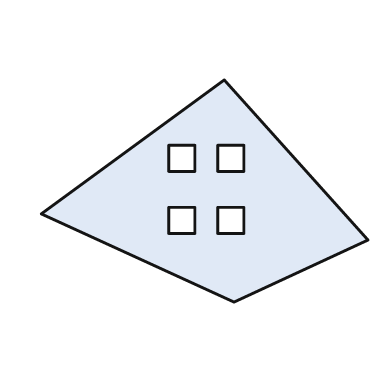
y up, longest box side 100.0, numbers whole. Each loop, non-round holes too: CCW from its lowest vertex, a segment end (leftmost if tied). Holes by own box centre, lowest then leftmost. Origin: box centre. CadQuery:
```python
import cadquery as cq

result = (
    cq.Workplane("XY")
    .moveTo(9.0, -34.0)
    .lineTo(50.0, -15.0)
    .lineTo(6.0, 34.0)
    .lineTo(-50.0, -7.0)
    .close()
    .moveTo(-11.0, -13.0)
    .lineTo(-3.0, -13.0)
    .lineTo(-3.0, -5.0)
    .lineTo(-11.0, -5.0)
    .close()
    .moveTo(4.0, -13.0)
    .lineTo(12.0, -13.0)
    .lineTo(12.0, -5.0)
    .lineTo(4.0, -5.0)
    .close()
    .moveTo(-11.0, 6.0)
    .lineTo(-3.0, 6.0)
    .lineTo(-3.0, 14.0)
    .lineTo(-11.0, 14.0)
    .close()
    .moveTo(4.0, 6.0)
    .lineTo(12.0, 6.0)
    .lineTo(12.0, 14.0)
    .lineTo(4.0, 14.0)
    .close()
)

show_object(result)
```